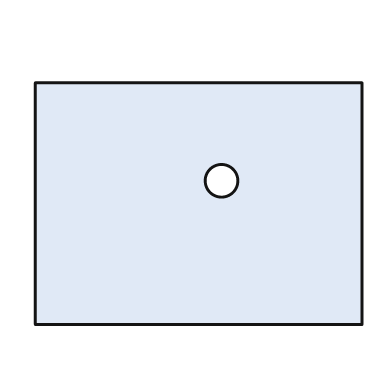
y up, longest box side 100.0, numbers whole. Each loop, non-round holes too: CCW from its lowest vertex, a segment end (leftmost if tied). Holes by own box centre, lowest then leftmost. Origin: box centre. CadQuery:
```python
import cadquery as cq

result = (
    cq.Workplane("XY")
    .moveTo(-50.0, -37.0)
    .lineTo(50.0, -37.0)
    .lineTo(50.0, 37.0)
    .lineTo(-50.0, 37.0)
    .close()
    .moveTo(7.0, 7.0)
    .circle(5.0)
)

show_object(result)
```